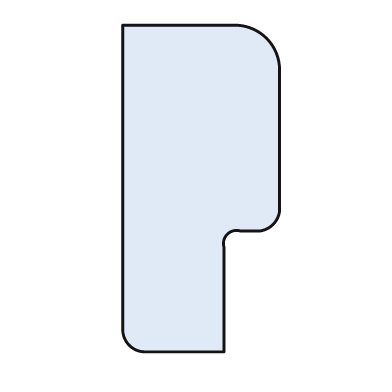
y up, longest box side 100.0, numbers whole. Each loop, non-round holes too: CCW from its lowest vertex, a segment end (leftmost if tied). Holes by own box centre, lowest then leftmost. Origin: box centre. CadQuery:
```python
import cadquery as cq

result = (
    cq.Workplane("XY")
    .moveTo(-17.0, -50.0)
    .lineTo(7.0, -50.0)
    .lineTo(7.0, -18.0)
    .threePointArc((8.0, -14.0), (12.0, -13.0))
    .lineTo(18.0, -13.0)
    .threePointArc((22.0, -11.0), (24.0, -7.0))
    .lineTo(24.0, 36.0)
    .threePointArc((20.0, 46.0), (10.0, 50.0))
    .lineTo(-24.0, 50.0)
    .lineTo(-24.0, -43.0)
    .threePointArc((-22.0, -48.0), (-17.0, -50.0))
    .close()
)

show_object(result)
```